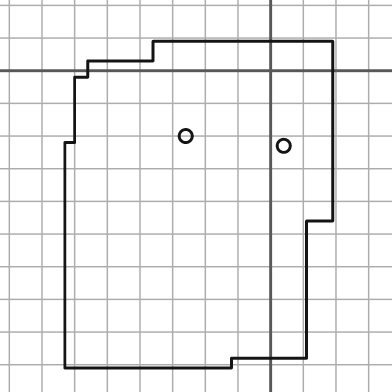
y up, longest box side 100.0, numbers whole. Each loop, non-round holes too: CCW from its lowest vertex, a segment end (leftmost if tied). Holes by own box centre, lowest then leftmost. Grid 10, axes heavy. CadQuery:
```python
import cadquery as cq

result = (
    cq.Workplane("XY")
    .moveTo(-63.0, -91.0)
    .lineTo(-12.0, -91.0)
    .lineTo(-12.0, -88.0)
    .lineTo(11.0, -88.0)
    .lineTo(11.0, -46.0)
    .lineTo(19.0, -46.0)
    .lineTo(19.0, 9.0)
    .lineTo(-36.0, 9.0)
    .lineTo(-36.0, 3.0)
    .lineTo(-56.0, 3.0)
    .lineTo(-56.0, -2.0)
    .lineTo(-60.0, -2.0)
    .lineTo(-60.0, -22.0)
    .lineTo(-63.0, -22.0)
    .close()
    .moveTo(4.0, -23.0)
    .circle(2.0)
    .moveTo(-26.0, -20.0)
    .circle(2.0)
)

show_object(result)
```